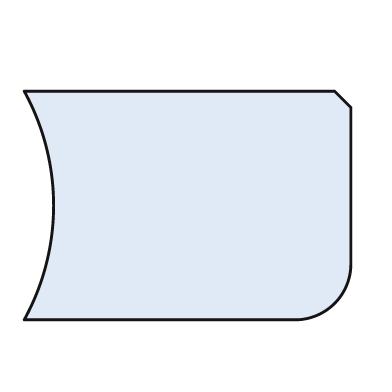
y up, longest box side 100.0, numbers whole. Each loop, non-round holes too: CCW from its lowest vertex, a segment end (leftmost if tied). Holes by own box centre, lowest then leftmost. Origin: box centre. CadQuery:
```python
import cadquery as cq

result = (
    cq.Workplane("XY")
    .moveTo(-50.0, -35.0)
    .lineTo(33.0, -35.0)
    .threePointArc((45.0, -30.0), (50.0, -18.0))
    .lineTo(50.0, 30.0)
    .lineTo(45.0, 35.0)
    .lineTo(-50.0, 35.0)
    .threePointArc((-41.0, 0.0), (-50.0, -35.0))
    .close()
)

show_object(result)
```